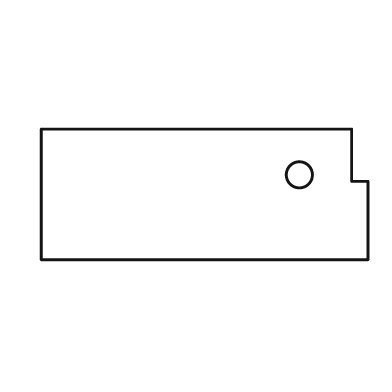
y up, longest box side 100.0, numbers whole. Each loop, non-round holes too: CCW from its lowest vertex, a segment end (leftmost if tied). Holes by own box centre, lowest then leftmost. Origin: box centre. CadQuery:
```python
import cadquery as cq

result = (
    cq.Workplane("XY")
    .moveTo(-50.0, -20.0)
    .lineTo(50.0, -20.0)
    .lineTo(50.0, 4.0)
    .lineTo(45.0, 4.0)
    .lineTo(45.0, 20.0)
    .lineTo(-50.0, 20.0)
    .close()
    .moveTo(29.0, 6.0)
    .circle(4.0)
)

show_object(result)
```